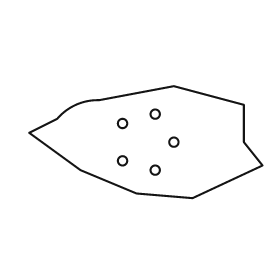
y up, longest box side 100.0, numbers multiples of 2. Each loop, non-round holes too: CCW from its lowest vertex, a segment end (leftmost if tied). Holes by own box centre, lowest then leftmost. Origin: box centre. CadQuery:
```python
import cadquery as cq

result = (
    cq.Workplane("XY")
    .moveTo(20.0, -24.0)
    .lineTo(50.0, -10.0)
    .lineTo(42.0, 0.0)
    .lineTo(42.0, 16.0)
    .lineTo(12.0, 24.0)
    .lineTo(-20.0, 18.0)
    .threePointArc((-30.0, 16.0), (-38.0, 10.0))
    .lineTo(-50.0, 4.0)
    .lineTo(-28.0, -12.0)
    .lineTo(-4.0, -22.0)
    .close()
    .moveTo(4.0, -12.0)
    .circle(2.0)
    .moveTo(-10.0, -8.0)
    .circle(2.0)
    .moveTo(12.0, 0.0)
    .circle(2.0)
    .moveTo(-10.0, 8.0)
    .circle(2.0)
    .moveTo(4.0, 12.0)
    .circle(2.0)
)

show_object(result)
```